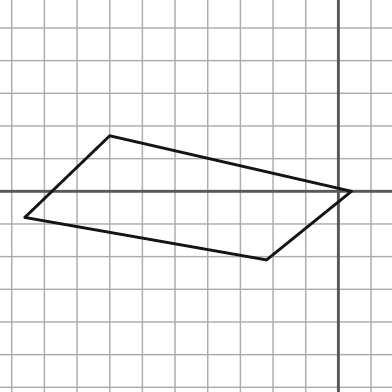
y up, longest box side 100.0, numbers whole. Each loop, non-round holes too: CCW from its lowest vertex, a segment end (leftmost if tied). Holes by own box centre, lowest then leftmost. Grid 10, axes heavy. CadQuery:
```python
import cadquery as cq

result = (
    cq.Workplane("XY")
    .moveTo(-22.0, -21.0)
    .lineTo(4.0, 0.0)
    .lineTo(-70.0, 17.0)
    .lineTo(-96.0, -8.0)
    .close()
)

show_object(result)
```